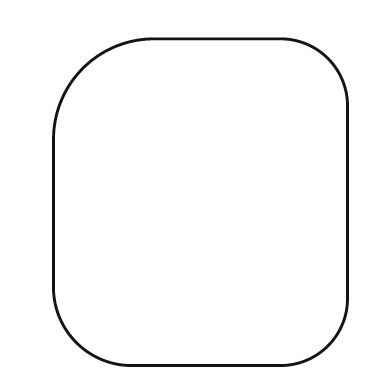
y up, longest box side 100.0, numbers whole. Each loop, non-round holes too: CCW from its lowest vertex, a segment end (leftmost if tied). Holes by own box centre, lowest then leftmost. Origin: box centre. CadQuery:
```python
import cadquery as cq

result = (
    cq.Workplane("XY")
    .moveTo(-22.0, -50.0)
    .lineTo(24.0, -50.0)
    .threePointArc((39.0, -44.0), (45.0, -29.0))
    .lineTo(45.0, 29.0)
    .threePointArc((39.0, 44.0), (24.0, 50.0))
    .lineTo(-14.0, 50.0)
    .threePointArc((-36.0, 41.0), (-45.0, 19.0))
    .lineTo(-45.0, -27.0)
    .threePointArc((-38.0, -43.0), (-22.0, -50.0))
    .close()
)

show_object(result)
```